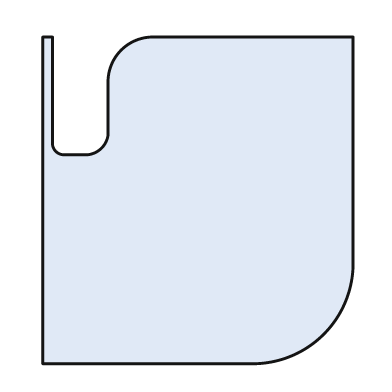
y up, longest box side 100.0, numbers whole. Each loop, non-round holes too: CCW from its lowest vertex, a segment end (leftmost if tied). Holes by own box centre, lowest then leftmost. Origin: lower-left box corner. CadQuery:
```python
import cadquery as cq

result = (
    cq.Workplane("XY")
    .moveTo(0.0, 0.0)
    .lineTo(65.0, 0.0)
    .threePointArc((86.0, 9.0), (95.0, 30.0))
    .lineTo(95.0, 100.0)
    .lineTo(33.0, 100.0)
    .threePointArc((24.0, 96.0), (20.0, 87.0))
    .lineTo(20.0, 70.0)
    .threePointArc((18.0, 66.0), (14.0, 64.0))
    .lineTo(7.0, 64.0)
    .threePointArc((4.0, 65.0), (3.0, 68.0))
    .lineTo(3.0, 100.0)
    .lineTo(0.0, 100.0)
    .close()
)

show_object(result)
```